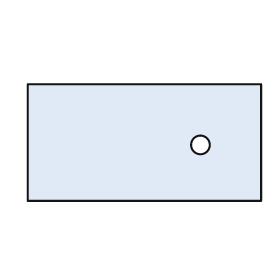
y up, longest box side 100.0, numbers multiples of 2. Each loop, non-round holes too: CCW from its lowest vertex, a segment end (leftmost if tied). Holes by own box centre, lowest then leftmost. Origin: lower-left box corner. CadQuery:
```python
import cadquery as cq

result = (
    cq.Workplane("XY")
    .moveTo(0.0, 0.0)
    .lineTo(100.0, 0.0)
    .lineTo(100.0, 50.0)
    .lineTo(0.0, 50.0)
    .close()
    .moveTo(74.0, 24.0)
    .circle(4.0)
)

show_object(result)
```